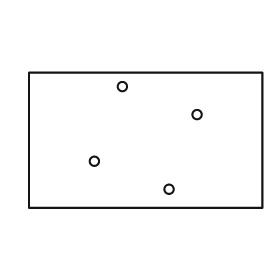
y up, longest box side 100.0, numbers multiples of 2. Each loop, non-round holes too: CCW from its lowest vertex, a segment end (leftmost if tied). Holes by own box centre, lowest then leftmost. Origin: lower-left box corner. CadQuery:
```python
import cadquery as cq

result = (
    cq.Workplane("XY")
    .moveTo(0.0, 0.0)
    .lineTo(100.0, 0.0)
    .lineTo(100.0, 58.0)
    .lineTo(0.0, 58.0)
    .close()
    .moveTo(60.0, 8.0)
    .circle(2.0)
    .moveTo(28.0, 20.0)
    .circle(2.0)
    .moveTo(72.0, 40.0)
    .circle(2.0)
    .moveTo(40.0, 52.0)
    .circle(2.0)
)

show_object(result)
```